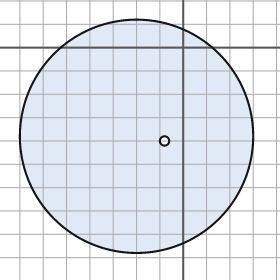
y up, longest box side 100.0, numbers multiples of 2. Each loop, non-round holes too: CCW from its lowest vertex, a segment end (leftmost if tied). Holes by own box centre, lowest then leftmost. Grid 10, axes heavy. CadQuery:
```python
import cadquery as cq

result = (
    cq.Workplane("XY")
    .moveTo(-20.0, -38.0)
    .circle(50.0)
    .moveTo(-8.0, -40.0)
    .circle(2.0)
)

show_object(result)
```